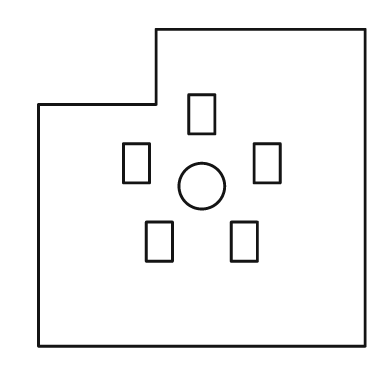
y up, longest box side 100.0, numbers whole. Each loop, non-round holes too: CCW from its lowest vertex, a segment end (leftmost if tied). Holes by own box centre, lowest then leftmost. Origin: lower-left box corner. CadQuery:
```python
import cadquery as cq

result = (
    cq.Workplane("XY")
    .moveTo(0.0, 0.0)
    .lineTo(100.0, 0.0)
    .lineTo(100.0, 97.0)
    .lineTo(36.0, 97.0)
    .lineTo(36.0, 74.0)
    .lineTo(0.0, 74.0)
    .close()
    .moveTo(33.0, 26.0)
    .lineTo(41.0, 26.0)
    .lineTo(41.0, 38.0)
    .lineTo(33.0, 38.0)
    .close()
    .moveTo(59.0, 26.0)
    .lineTo(67.0, 26.0)
    .lineTo(67.0, 38.0)
    .lineTo(59.0, 38.0)
    .close()
    .moveTo(50.0, 49.0)
    .circle(7.0)
    .moveTo(26.0, 50.0)
    .lineTo(34.0, 50.0)
    .lineTo(34.0, 62.0)
    .lineTo(26.0, 62.0)
    .close()
    .moveTo(66.0, 50.0)
    .lineTo(74.0, 50.0)
    .lineTo(74.0, 62.0)
    .lineTo(66.0, 62.0)
    .close()
    .moveTo(46.0, 65.0)
    .lineTo(54.0, 65.0)
    .lineTo(54.0, 77.0)
    .lineTo(46.0, 77.0)
    .close()
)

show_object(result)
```